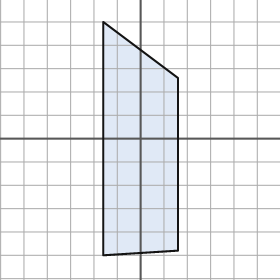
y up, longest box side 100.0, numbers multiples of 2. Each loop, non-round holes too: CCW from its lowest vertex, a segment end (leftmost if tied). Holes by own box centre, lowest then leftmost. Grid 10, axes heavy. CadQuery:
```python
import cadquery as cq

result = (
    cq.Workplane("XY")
    .moveTo(-16.0, -50.0)
    .lineTo(16.0, -48.0)
    .lineTo(16.0, 26.0)
    .lineTo(-16.0, 50.0)
    .close()
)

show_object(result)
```